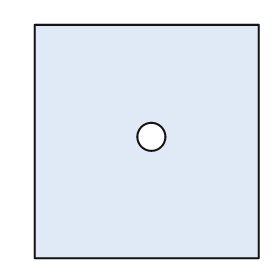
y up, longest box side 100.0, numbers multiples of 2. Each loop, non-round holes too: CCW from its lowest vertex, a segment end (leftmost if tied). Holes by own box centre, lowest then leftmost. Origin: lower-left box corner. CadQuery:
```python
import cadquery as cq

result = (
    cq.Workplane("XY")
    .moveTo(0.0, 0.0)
    .lineTo(96.0, 0.0)
    .lineTo(96.0, 100.0)
    .lineTo(0.0, 100.0)
    .close()
    .moveTo(50.0, 52.0)
    .circle(6.0)
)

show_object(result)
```